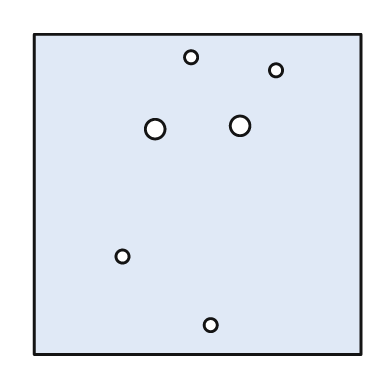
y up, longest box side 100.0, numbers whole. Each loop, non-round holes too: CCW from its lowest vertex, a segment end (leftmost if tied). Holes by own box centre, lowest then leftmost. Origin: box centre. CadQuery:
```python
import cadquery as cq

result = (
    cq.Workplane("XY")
    .moveTo(-50.0, -49.0)
    .lineTo(50.0, -49.0)
    .lineTo(50.0, 49.0)
    .lineTo(-50.0, 49.0)
    .close()
    .moveTo(4.0, -40.0)
    .circle(2.0)
    .moveTo(-23.0, -19.0)
    .circle(2.0)
    .moveTo(-13.0, 20.0)
    .circle(3.0)
    .moveTo(13.0, 21.0)
    .circle(3.0)
    .moveTo(24.0, 38.0)
    .circle(2.0)
    .moveTo(-2.0, 42.0)
    .circle(2.0)
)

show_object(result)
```